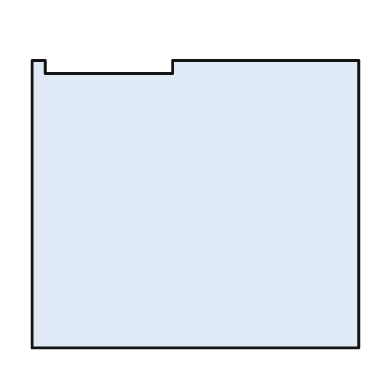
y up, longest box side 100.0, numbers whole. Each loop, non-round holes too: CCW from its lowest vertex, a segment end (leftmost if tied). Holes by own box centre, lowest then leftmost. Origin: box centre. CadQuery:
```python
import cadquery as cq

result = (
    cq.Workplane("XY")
    .moveTo(-50.0, -44.0)
    .lineTo(50.0, -44.0)
    .lineTo(50.0, 44.0)
    .lineTo(-7.0, 44.0)
    .lineTo(-7.0, 40.0)
    .lineTo(-46.0, 40.0)
    .lineTo(-46.0, 44.0)
    .lineTo(-50.0, 44.0)
    .close()
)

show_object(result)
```